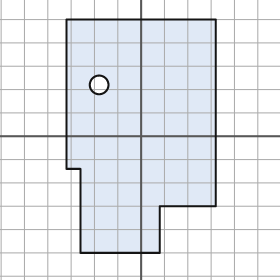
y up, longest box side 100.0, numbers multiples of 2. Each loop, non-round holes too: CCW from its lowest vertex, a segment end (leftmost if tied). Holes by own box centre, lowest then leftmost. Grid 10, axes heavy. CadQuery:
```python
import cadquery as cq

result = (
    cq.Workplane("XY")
    .moveTo(-26.0, -50.0)
    .lineTo(8.0, -50.0)
    .lineTo(8.0, -30.0)
    .lineTo(32.0, -30.0)
    .lineTo(32.0, 50.0)
    .lineTo(-32.0, 50.0)
    .lineTo(-32.0, -14.0)
    .lineTo(-26.0, -14.0)
    .close()
    .moveTo(-18.0, 22.0)
    .circle(4.0)
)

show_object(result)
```